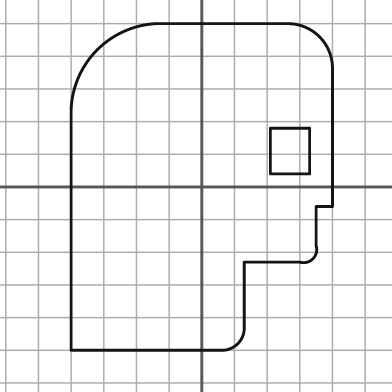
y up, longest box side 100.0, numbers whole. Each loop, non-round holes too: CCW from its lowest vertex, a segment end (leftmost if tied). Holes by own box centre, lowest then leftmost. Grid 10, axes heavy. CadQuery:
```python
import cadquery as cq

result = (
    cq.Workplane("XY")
    .moveTo(-40.0, -50.0)
    .lineTo(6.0, -50.0)
    .threePointArc((11.0, -48.0), (13.0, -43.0))
    .lineTo(13.0, -23.0)
    .lineTo(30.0, -23.0)
    .threePointArc((34.0, -22.0), (35.0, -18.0))
    .lineTo(35.0, -6.0)
    .lineTo(40.0, -6.0)
    .lineTo(40.0, 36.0)
    .threePointArc((36.0, 46.0), (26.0, 50.0))
    .lineTo(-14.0, 50.0)
    .threePointArc((-32.0, 42.0), (-40.0, 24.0))
    .close()
    .moveTo(21.0, 4.0)
    .lineTo(33.0, 4.0)
    .lineTo(33.0, 18.0)
    .lineTo(21.0, 18.0)
    .close()
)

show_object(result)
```